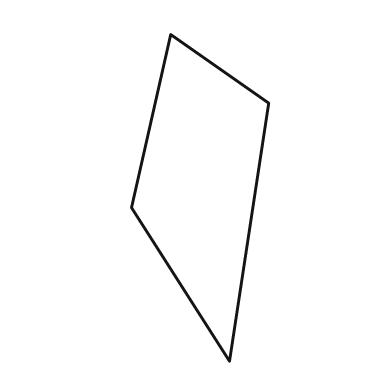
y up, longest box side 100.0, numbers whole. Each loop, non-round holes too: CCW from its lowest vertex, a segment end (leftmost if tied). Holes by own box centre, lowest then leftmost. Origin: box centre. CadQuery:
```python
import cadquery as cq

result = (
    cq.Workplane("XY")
    .moveTo(9.0, -50.0)
    .lineTo(21.0, 29.0)
    .lineTo(-9.0, 50.0)
    .lineTo(-21.0, -3.0)
    .close()
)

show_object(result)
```